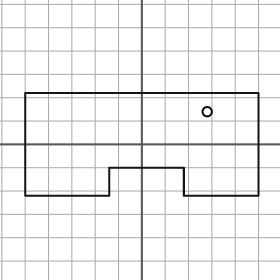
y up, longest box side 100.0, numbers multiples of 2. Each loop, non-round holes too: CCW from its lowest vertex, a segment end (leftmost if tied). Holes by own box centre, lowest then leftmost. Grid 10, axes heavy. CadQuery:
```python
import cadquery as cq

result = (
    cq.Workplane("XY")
    .moveTo(-50.0, -22.0)
    .lineTo(-14.0, -22.0)
    .lineTo(-14.0, -10.0)
    .lineTo(18.0, -10.0)
    .lineTo(18.0, -22.0)
    .lineTo(50.0, -22.0)
    .lineTo(50.0, 22.0)
    .lineTo(-50.0, 22.0)
    .close()
    .moveTo(28.0, 14.0)
    .circle(2.0)
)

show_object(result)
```